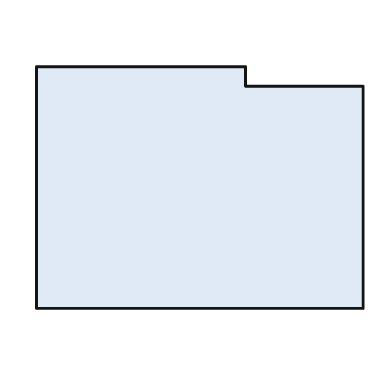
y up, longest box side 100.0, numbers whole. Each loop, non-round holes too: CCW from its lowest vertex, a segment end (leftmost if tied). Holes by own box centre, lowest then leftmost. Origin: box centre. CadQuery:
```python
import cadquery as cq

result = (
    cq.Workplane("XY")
    .moveTo(-50.0, -37.0)
    .lineTo(50.0, -37.0)
    .lineTo(50.0, 31.0)
    .lineTo(14.0, 31.0)
    .lineTo(14.0, 37.0)
    .lineTo(-50.0, 37.0)
    .close()
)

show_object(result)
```